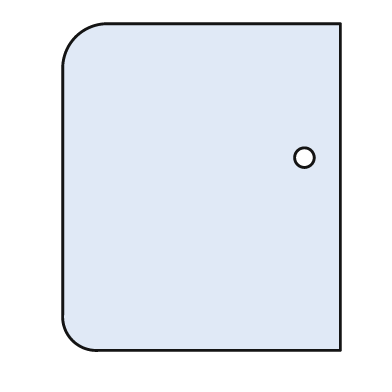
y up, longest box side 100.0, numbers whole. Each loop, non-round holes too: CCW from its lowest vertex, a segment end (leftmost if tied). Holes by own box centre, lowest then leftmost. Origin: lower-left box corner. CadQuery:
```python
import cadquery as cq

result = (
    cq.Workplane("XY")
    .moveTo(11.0, 0.0)
    .lineTo(85.0, 0.0)
    .lineTo(85.0, 100.0)
    .lineTo(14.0, 100.0)
    .threePointArc((4.0, 96.0), (0.0, 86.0))
    .lineTo(0.0, 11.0)
    .threePointArc((3.0, 3.0), (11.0, 0.0))
    .close()
    .moveTo(74.0, 59.0)
    .circle(3.0)
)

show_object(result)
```